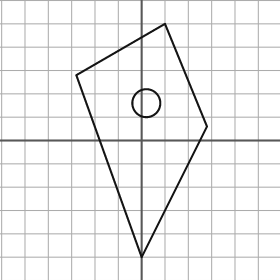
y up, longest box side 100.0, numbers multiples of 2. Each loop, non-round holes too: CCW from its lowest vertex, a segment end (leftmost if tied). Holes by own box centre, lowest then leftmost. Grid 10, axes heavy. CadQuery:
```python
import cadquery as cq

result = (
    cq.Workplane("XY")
    .moveTo(0.0, -50.0)
    .lineTo(28.0, 6.0)
    .lineTo(10.0, 50.0)
    .lineTo(-28.0, 28.0)
    .close()
    .moveTo(2.0, 16.0)
    .circle(6.0)
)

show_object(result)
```